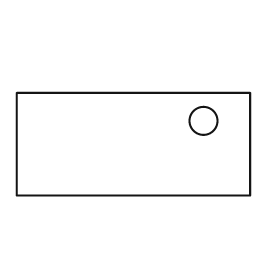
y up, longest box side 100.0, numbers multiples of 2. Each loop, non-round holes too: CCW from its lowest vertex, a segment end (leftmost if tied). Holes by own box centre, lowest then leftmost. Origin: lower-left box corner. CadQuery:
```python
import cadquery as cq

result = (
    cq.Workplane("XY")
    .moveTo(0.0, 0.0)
    .lineTo(100.0, 0.0)
    .lineTo(100.0, 44.0)
    .lineTo(0.0, 44.0)
    .close()
    .moveTo(80.0, 32.0)
    .circle(6.0)
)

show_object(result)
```